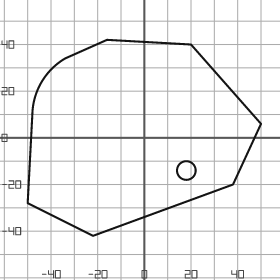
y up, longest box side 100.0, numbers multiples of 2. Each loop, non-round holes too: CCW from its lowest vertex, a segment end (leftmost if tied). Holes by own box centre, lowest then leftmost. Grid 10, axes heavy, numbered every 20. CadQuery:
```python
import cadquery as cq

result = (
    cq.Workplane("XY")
    .moveTo(-22.0, -42.0)
    .lineTo(38.0, -20.0)
    .lineTo(50.0, 6.0)
    .lineTo(20.0, 40.0)
    .lineTo(-16.0, 42.0)
    .lineTo(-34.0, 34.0)
    .threePointArc((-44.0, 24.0), (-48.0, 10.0))
    .lineTo(-50.0, -28.0)
    .close()
    .moveTo(18.0, -14.0)
    .circle(4.0)
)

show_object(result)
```